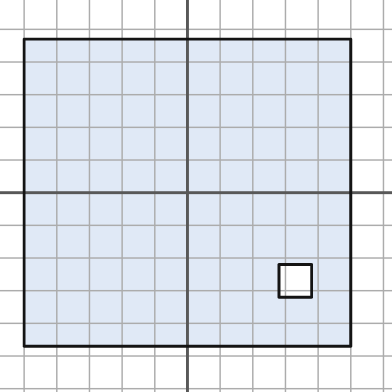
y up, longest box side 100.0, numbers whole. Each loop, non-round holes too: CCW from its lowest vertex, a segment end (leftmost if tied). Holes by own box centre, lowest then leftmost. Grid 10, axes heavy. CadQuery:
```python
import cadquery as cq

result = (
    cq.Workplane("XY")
    .moveTo(-50.0, -47.0)
    .lineTo(50.0, -47.0)
    .lineTo(50.0, 47.0)
    .lineTo(-50.0, 47.0)
    .close()
    .moveTo(28.0, -32.0)
    .lineTo(38.0, -32.0)
    .lineTo(38.0, -22.0)
    .lineTo(28.0, -22.0)
    .close()
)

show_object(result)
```